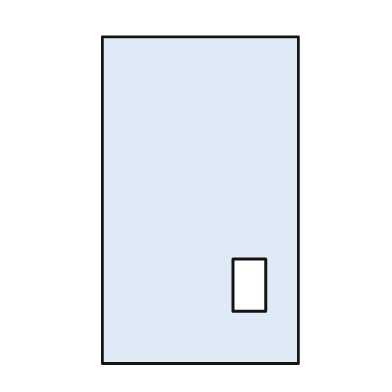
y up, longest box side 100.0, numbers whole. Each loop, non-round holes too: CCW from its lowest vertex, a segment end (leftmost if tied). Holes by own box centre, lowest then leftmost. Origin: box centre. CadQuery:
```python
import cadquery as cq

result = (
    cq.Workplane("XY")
    .moveTo(-30.0, -50.0)
    .lineTo(30.0, -50.0)
    .lineTo(30.0, 50.0)
    .lineTo(-30.0, 50.0)
    .close()
    .moveTo(10.0, -34.0)
    .lineTo(20.0, -34.0)
    .lineTo(20.0, -18.0)
    .lineTo(10.0, -18.0)
    .close()
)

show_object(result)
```